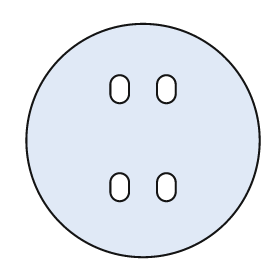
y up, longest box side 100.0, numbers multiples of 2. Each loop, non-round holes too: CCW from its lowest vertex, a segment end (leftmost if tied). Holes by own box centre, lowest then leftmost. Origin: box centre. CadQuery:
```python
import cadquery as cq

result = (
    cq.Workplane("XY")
    .moveTo(0.0, 0.0)
    .circle(50.0)
    .moveTo(-14.0, -22.0)
    .threePointArc((-10.0, -26.0), (-6.0, -22.0))
    .lineTo(-6.0, -18.0)
    .threePointArc((-10.0, -14.0), (-14.0, -18.0))
    .close()
    .moveTo(6.0, -22.0)
    .threePointArc((10.0, -26.0), (14.0, -22.0))
    .lineTo(14.0, -18.0)
    .threePointArc((10.0, -14.0), (6.0, -18.0))
    .close()
    .moveTo(-14.0, 20.0)
    .threePointArc((-10.0, 16.0), (-6.0, 20.0))
    .lineTo(-6.0, 24.0)
    .threePointArc((-10.0, 28.0), (-14.0, 24.0))
    .close()
    .moveTo(6.0, 20.0)
    .threePointArc((10.0, 16.0), (14.0, 20.0))
    .lineTo(14.0, 24.0)
    .threePointArc((10.0, 28.0), (6.0, 24.0))
    .close()
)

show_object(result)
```